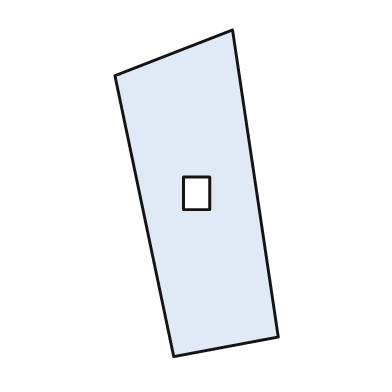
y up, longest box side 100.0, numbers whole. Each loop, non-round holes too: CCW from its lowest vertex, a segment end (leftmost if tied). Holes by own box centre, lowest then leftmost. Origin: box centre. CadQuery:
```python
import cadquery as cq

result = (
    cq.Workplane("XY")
    .moveTo(-7.0, -50.0)
    .lineTo(25.0, -44.0)
    .lineTo(11.0, 50.0)
    .lineTo(-25.0, 36.0)
    .close()
    .moveTo(-4.0, -5.0)
    .lineTo(4.0, -5.0)
    .lineTo(4.0, 5.0)
    .lineTo(-4.0, 5.0)
    .close()
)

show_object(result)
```